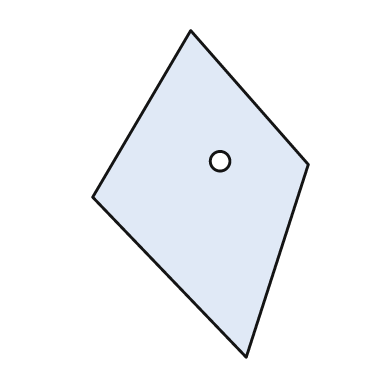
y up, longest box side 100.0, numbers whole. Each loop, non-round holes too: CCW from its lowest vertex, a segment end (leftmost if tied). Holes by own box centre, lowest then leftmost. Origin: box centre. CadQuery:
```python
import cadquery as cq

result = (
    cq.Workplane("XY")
    .moveTo(14.0, -50.0)
    .lineTo(33.0, 9.0)
    .lineTo(-3.0, 50.0)
    .lineTo(-33.0, -1.0)
    .close()
    .moveTo(6.0, 10.0)
    .circle(3.0)
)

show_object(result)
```